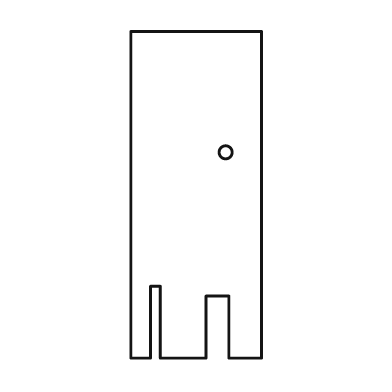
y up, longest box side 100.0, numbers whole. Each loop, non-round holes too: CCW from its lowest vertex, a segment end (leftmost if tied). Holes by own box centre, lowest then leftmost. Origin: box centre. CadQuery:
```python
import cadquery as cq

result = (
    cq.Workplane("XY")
    .moveTo(-20.0, -50.0)
    .lineTo(-14.0, -50.0)
    .lineTo(-14.0, -28.0)
    .lineTo(-11.0, -28.0)
    .lineTo(-11.0, -50.0)
    .lineTo(3.0, -50.0)
    .lineTo(3.0, -31.0)
    .lineTo(10.0, -31.0)
    .lineTo(10.0, -50.0)
    .lineTo(20.0, -50.0)
    .lineTo(20.0, 50.0)
    .lineTo(-20.0, 50.0)
    .close()
    .moveTo(9.0, 13.0)
    .circle(2.0)
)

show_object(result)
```